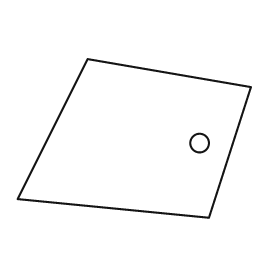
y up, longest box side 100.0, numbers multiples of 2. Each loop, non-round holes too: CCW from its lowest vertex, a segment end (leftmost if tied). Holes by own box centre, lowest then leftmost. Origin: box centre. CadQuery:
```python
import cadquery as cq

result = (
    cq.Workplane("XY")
    .moveTo(32.0, -34.0)
    .lineTo(50.0, 22.0)
    .lineTo(-20.0, 34.0)
    .lineTo(-50.0, -26.0)
    .close()
    .moveTo(28.0, -2.0)
    .circle(4.0)
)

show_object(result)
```